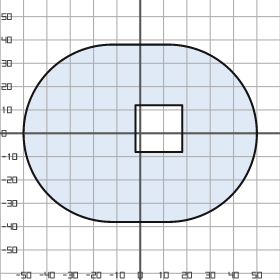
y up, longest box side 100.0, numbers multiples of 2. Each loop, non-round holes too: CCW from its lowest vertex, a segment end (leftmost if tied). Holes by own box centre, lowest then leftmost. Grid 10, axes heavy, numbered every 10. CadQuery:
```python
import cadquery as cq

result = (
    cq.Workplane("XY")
    .moveTo(-12.0, -38.0)
    .lineTo(12.0, -38.0)
    .threePointArc((50.0, 0.0), (12.0, 38.0))
    .lineTo(-12.0, 38.0)
    .threePointArc((-50.0, 0.0), (-12.0, -38.0))
    .close()
    .moveTo(-2.0, -8.0)
    .lineTo(18.0, -8.0)
    .lineTo(18.0, 12.0)
    .lineTo(-2.0, 12.0)
    .close()
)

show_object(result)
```